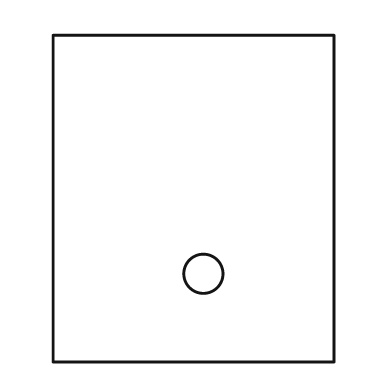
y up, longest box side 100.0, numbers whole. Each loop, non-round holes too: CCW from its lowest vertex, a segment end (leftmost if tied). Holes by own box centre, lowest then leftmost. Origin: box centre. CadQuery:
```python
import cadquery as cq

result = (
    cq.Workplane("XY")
    .moveTo(-43.0, -50.0)
    .lineTo(43.0, -50.0)
    .lineTo(43.0, 50.0)
    .lineTo(-43.0, 50.0)
    .close()
    .moveTo(3.0, -23.0)
    .circle(6.0)
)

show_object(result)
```